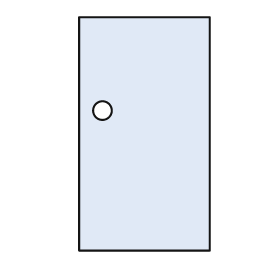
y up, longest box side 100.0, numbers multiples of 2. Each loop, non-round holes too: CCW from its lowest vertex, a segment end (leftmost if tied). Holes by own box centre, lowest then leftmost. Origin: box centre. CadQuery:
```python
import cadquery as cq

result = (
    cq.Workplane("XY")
    .moveTo(-28.0, -50.0)
    .lineTo(28.0, -50.0)
    .lineTo(28.0, 50.0)
    .lineTo(-28.0, 50.0)
    .close()
    .moveTo(-18.0, 10.0)
    .circle(4.0)
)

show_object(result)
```